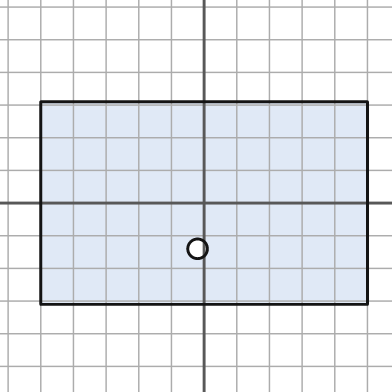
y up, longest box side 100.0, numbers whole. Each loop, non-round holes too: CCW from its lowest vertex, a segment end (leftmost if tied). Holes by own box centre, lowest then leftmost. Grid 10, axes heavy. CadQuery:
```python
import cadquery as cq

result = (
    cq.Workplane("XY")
    .moveTo(-50.0, -31.0)
    .lineTo(50.0, -31.0)
    .lineTo(50.0, 31.0)
    .lineTo(-50.0, 31.0)
    .close()
    .moveTo(-2.0, -14.0)
    .circle(3.0)
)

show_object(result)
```